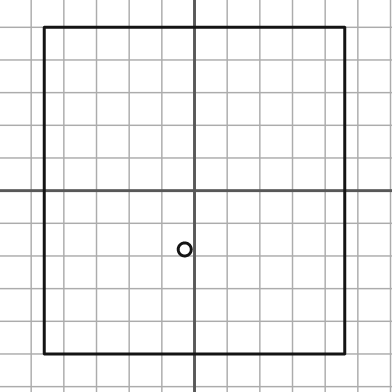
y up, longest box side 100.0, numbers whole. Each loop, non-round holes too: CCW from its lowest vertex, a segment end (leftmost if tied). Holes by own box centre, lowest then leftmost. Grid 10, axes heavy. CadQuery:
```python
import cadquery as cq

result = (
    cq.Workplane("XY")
    .moveTo(-46.0, -50.0)
    .lineTo(46.0, -50.0)
    .lineTo(46.0, 50.0)
    .lineTo(-46.0, 50.0)
    .close()
    .moveTo(-3.0, -18.0)
    .circle(2.0)
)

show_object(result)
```